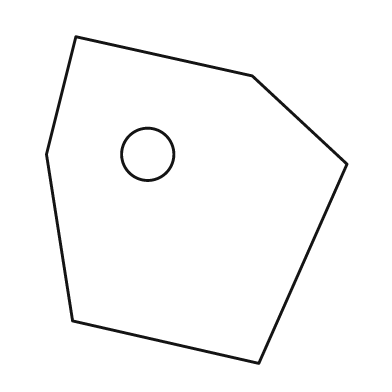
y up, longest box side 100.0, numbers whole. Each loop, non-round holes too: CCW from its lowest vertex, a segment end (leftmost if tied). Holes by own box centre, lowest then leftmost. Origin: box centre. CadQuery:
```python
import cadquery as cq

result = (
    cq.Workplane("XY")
    .moveTo(19.0, -50.0)
    .lineTo(46.0, 11.0)
    .lineTo(17.0, 38.0)
    .lineTo(-37.0, 50.0)
    .lineTo(-46.0, 14.0)
    .lineTo(-38.0, -37.0)
    .close()
    .moveTo(-15.0, 14.0)
    .circle(8.0)
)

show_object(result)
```